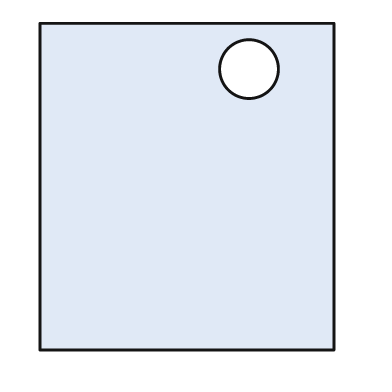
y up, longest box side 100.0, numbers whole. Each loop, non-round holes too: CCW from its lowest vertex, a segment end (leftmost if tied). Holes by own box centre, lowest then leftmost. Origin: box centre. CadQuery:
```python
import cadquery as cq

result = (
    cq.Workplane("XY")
    .moveTo(-45.0, -50.0)
    .lineTo(45.0, -50.0)
    .lineTo(45.0, 50.0)
    .lineTo(-45.0, 50.0)
    .close()
    .moveTo(19.0, 36.0)
    .circle(9.0)
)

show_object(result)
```